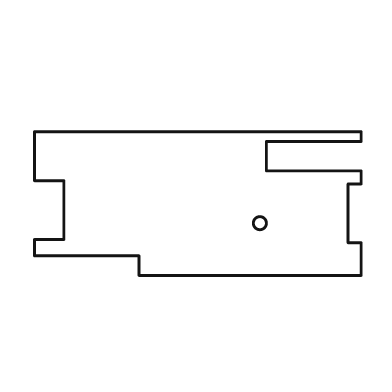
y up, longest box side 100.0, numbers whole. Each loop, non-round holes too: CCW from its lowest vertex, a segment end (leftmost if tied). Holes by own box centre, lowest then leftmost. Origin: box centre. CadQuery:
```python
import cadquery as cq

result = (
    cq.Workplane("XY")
    .moveTo(-18.0, -22.0)
    .lineTo(50.0, -22.0)
    .lineTo(50.0, -12.0)
    .lineTo(46.0, -12.0)
    .lineTo(46.0, 6.0)
    .lineTo(50.0, 6.0)
    .lineTo(50.0, 10.0)
    .lineTo(21.0, 10.0)
    .lineTo(21.0, 19.0)
    .lineTo(50.0, 19.0)
    .lineTo(50.0, 22.0)
    .lineTo(-50.0, 22.0)
    .lineTo(-50.0, 7.0)
    .lineTo(-41.0, 7.0)
    .lineTo(-41.0, -11.0)
    .lineTo(-50.0, -11.0)
    .lineTo(-50.0, -16.0)
    .lineTo(-18.0, -16.0)
    .close()
    .moveTo(19.0, -6.0)
    .circle(2.0)
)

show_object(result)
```